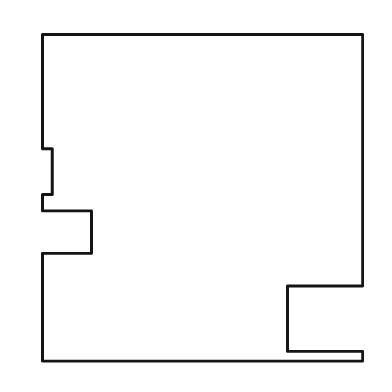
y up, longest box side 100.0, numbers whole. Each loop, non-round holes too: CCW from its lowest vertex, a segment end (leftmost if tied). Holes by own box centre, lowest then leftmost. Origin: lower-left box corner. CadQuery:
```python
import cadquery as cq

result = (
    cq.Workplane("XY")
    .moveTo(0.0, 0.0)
    .lineTo(98.0, 0.0)
    .lineTo(98.0, 3.0)
    .lineTo(75.0, 3.0)
    .lineTo(75.0, 23.0)
    .lineTo(98.0, 23.0)
    .lineTo(98.0, 100.0)
    .lineTo(0.0, 100.0)
    .lineTo(0.0, 65.0)
    .lineTo(3.0, 65.0)
    .lineTo(3.0, 51.0)
    .lineTo(0.0, 51.0)
    .lineTo(0.0, 46.0)
    .lineTo(15.0, 46.0)
    .lineTo(15.0, 33.0)
    .lineTo(0.0, 33.0)
    .close()
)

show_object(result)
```